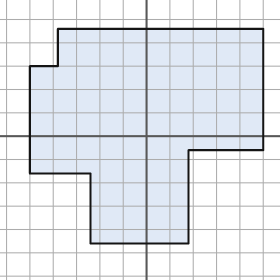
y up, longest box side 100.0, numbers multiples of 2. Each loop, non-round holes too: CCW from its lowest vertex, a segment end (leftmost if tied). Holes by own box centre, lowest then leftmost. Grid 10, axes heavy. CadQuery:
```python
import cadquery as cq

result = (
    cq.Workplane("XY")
    .moveTo(-24.0, -46.0)
    .lineTo(18.0, -46.0)
    .lineTo(18.0, -6.0)
    .lineTo(50.0, -6.0)
    .lineTo(50.0, 46.0)
    .lineTo(-38.0, 46.0)
    .lineTo(-38.0, 30.0)
    .lineTo(-50.0, 30.0)
    .lineTo(-50.0, -16.0)
    .lineTo(-24.0, -16.0)
    .close()
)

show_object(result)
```